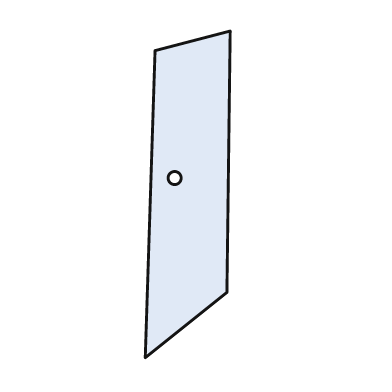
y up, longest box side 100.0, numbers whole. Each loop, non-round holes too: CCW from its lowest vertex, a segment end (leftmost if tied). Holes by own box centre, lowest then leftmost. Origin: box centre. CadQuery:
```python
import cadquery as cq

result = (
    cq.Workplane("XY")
    .moveTo(-13.0, -50.0)
    .lineTo(12.0, -30.0)
    .lineTo(13.0, 50.0)
    .lineTo(-10.0, 44.0)
    .close()
    .moveTo(-4.0, 5.0)
    .circle(2.0)
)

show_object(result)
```